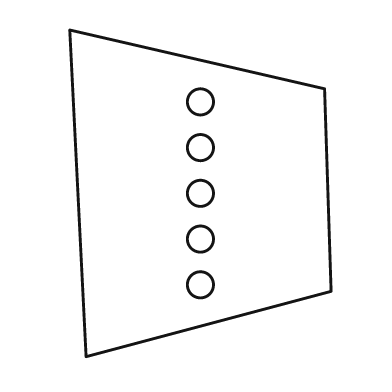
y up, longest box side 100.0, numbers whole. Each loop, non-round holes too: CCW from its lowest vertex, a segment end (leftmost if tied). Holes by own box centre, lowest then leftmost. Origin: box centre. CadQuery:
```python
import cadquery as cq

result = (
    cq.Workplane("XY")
    .moveTo(-35.0, -50.0)
    .lineTo(40.0, -30.0)
    .lineTo(38.0, 32.0)
    .lineTo(-40.0, 50.0)
    .close()
    .moveTo(0.0, -28.0)
    .circle(4.0)
    .moveTo(0.0, -14.0)
    .circle(4.0)
    .moveTo(0.0, 0.0)
    .circle(4.0)
    .moveTo(0.0, 14.0)
    .circle(4.0)
    .moveTo(0.0, 28.0)
    .circle(4.0)
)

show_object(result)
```